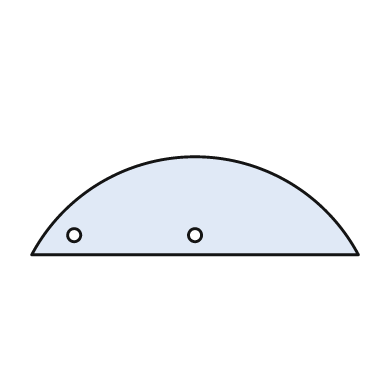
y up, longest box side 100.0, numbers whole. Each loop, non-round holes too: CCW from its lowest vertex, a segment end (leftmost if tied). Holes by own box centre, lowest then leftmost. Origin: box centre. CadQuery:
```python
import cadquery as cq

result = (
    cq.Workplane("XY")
    .moveTo(-50.0, -15.0)
    .lineTo(50.0, -15.0)
    .threePointArc((0.0, 15.0), (-50.0, -15.0))
    .close()
    .moveTo(-37.0, -9.0)
    .circle(2.0)
    .moveTo(0.0, -9.0)
    .circle(2.0)
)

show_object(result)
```